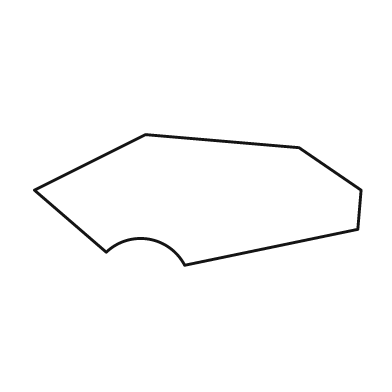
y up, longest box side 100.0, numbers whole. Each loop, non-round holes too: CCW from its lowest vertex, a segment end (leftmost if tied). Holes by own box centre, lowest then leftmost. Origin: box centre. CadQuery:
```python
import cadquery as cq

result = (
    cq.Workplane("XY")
    .moveTo(-4.0, -20.0)
    .lineTo(49.0, -9.0)
    .lineTo(50.0, 3.0)
    .lineTo(31.0, 16.0)
    .lineTo(-16.0, 20.0)
    .lineTo(-50.0, 3.0)
    .lineTo(-28.0, -16.0)
    .threePointArc((-15.0, -12.0), (-4.0, -20.0))
    .close()
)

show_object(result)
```